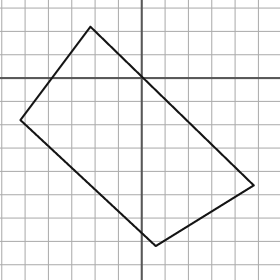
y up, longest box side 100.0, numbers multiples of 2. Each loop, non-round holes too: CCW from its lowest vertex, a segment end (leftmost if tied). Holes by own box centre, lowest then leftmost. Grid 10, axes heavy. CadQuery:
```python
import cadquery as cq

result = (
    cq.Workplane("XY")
    .moveTo(6.0, -72.0)
    .lineTo(48.0, -46.0)
    .lineTo(-22.0, 22.0)
    .lineTo(-52.0, -18.0)
    .close()
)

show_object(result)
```